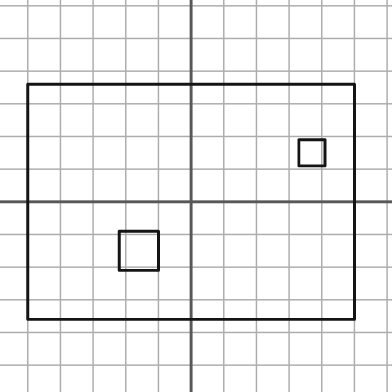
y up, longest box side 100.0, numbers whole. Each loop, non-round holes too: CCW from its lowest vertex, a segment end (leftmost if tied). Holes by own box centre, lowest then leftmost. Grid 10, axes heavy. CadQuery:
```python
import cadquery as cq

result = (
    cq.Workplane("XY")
    .moveTo(-50.0, -36.0)
    .lineTo(50.0, -36.0)
    .lineTo(50.0, 36.0)
    .lineTo(-50.0, 36.0)
    .close()
    .moveTo(-22.0, -21.0)
    .lineTo(-10.0, -21.0)
    .lineTo(-10.0, -9.0)
    .lineTo(-22.0, -9.0)
    .close()
    .moveTo(33.0, 11.0)
    .lineTo(41.0, 11.0)
    .lineTo(41.0, 19.0)
    .lineTo(33.0, 19.0)
    .close()
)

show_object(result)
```